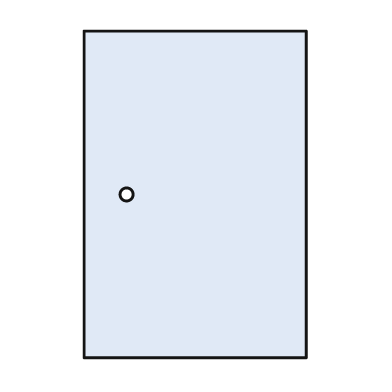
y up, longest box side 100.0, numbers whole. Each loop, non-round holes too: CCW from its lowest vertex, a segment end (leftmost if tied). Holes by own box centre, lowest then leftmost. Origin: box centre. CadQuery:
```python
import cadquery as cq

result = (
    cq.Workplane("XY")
    .moveTo(-34.0, -50.0)
    .lineTo(34.0, -50.0)
    .lineTo(34.0, 50.0)
    .lineTo(-34.0, 50.0)
    .close()
    .moveTo(-21.0, 0.0)
    .circle(2.0)
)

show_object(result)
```